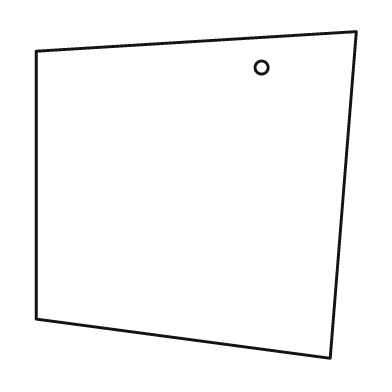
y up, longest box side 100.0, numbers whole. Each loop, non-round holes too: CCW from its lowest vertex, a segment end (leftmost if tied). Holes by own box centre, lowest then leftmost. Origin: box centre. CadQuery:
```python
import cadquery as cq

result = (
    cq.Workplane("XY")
    .moveTo(41.0, -50.0)
    .lineTo(49.0, 50.0)
    .lineTo(-49.0, 44.0)
    .lineTo(-49.0, -38.0)
    .close()
    .moveTo(20.0, 39.0)
    .circle(2.0)
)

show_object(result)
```